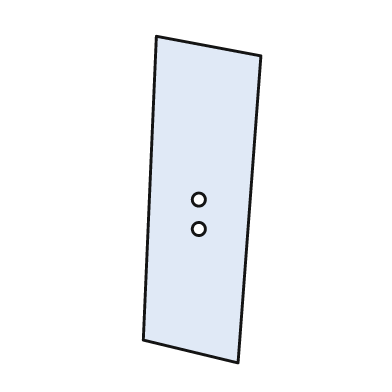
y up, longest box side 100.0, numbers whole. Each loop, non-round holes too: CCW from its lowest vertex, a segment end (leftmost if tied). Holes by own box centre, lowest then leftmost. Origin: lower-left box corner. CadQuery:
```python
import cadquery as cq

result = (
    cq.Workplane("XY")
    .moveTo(29.0, 0.0)
    .lineTo(36.0, 94.0)
    .lineTo(4.0, 100.0)
    .lineTo(0.0, 7.0)
    .close()
    .moveTo(17.0, 41.0)
    .circle(2.0)
    .moveTo(17.0, 50.0)
    .circle(2.0)
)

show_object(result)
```